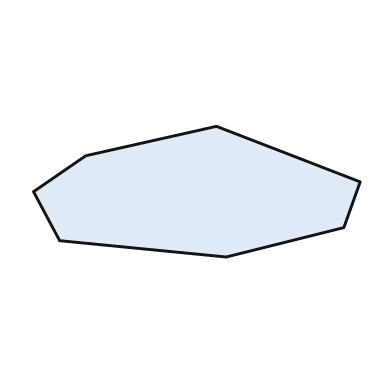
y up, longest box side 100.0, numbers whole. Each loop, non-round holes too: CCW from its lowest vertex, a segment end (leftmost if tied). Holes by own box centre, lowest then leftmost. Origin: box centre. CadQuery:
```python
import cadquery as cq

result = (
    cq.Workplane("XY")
    .moveTo(9.0, -20.0)
    .lineTo(45.0, -11.0)
    .lineTo(50.0, 3.0)
    .lineTo(6.0, 20.0)
    .lineTo(-34.0, 11.0)
    .lineTo(-50.0, 0.0)
    .lineTo(-42.0, -15.0)
    .close()
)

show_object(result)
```